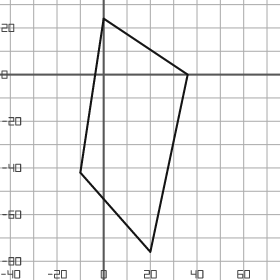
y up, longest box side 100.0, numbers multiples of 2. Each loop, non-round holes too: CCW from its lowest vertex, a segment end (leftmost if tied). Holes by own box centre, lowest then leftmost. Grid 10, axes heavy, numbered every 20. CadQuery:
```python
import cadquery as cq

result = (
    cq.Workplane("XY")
    .moveTo(20.0, -76.0)
    .lineTo(36.0, 0.0)
    .lineTo(0.0, 24.0)
    .lineTo(-10.0, -42.0)
    .close()
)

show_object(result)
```